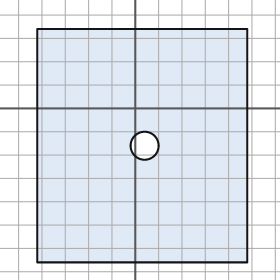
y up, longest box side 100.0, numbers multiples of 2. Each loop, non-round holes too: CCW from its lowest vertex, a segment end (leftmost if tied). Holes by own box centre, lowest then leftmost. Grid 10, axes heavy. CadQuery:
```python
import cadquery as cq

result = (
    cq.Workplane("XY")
    .moveTo(-42.0, -66.0)
    .lineTo(48.0, -66.0)
    .lineTo(48.0, 34.0)
    .lineTo(-42.0, 34.0)
    .close()
    .moveTo(4.0, -16.0)
    .circle(6.0)
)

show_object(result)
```